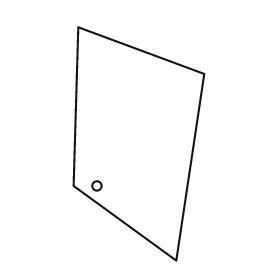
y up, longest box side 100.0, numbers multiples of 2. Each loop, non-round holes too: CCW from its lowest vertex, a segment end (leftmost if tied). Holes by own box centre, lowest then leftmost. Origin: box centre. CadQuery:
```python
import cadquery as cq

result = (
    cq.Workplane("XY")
    .moveTo(16.0, -50.0)
    .lineTo(28.0, 30.0)
    .lineTo(-26.0, 50.0)
    .lineTo(-28.0, -18.0)
    .close()
    .moveTo(-18.0, -18.0)
    .circle(2.0)
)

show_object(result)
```